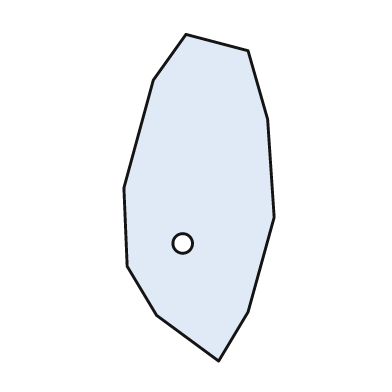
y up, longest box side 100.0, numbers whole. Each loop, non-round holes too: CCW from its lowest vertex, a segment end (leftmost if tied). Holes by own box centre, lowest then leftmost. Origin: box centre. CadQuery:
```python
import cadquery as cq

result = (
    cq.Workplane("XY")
    .moveTo(6.0, -50.0)
    .lineTo(15.0, -35.0)
    .lineTo(23.0, -6.0)
    .lineTo(21.0, 24.0)
    .lineTo(15.0, 45.0)
    .lineTo(-4.0, 50.0)
    .lineTo(-14.0, 36.0)
    .lineTo(-23.0, 3.0)
    .lineTo(-22.0, -21.0)
    .lineTo(-13.0, -36.0)
    .close()
    .moveTo(-5.0, -14.0)
    .circle(3.0)
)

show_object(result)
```